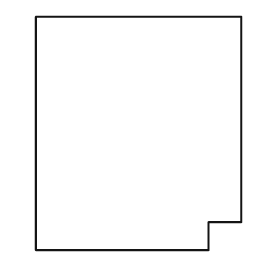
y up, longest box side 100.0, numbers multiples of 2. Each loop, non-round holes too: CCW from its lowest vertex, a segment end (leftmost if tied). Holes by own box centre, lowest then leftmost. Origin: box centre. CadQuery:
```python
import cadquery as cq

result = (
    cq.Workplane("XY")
    .moveTo(-44.0, -50.0)
    .lineTo(30.0, -50.0)
    .lineTo(30.0, -38.0)
    .lineTo(44.0, -38.0)
    .lineTo(44.0, 50.0)
    .lineTo(-44.0, 50.0)
    .close()
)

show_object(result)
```